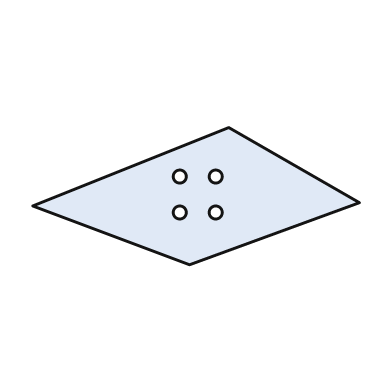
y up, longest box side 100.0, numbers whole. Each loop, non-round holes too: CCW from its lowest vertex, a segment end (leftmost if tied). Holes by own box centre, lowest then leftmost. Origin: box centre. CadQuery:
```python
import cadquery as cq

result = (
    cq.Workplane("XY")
    .moveTo(-2.0, -21.0)
    .lineTo(50.0, -2.0)
    .lineTo(10.0, 21.0)
    .lineTo(-50.0, -3.0)
    .close()
    .moveTo(-5.0, -5.0)
    .circle(2.0)
    .moveTo(6.0, -5.0)
    .circle(2.0)
    .moveTo(-5.0, 6.0)
    .circle(2.0)
    .moveTo(6.0, 6.0)
    .circle(2.0)
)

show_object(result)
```